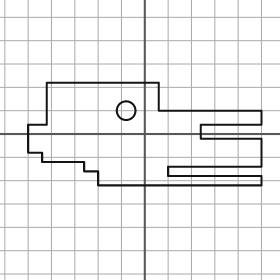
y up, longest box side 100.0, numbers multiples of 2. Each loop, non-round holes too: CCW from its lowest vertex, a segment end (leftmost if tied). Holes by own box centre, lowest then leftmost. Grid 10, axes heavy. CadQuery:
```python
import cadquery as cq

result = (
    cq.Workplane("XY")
    .moveTo(-20.0, -22.0)
    .lineTo(50.0, -22.0)
    .lineTo(50.0, -18.0)
    .lineTo(10.0, -18.0)
    .lineTo(10.0, -14.0)
    .lineTo(50.0, -14.0)
    .lineTo(50.0, -2.0)
    .lineTo(24.0, -2.0)
    .lineTo(24.0, 4.0)
    .lineTo(50.0, 4.0)
    .lineTo(50.0, 10.0)
    .lineTo(6.0, 10.0)
    .lineTo(6.0, 22.0)
    .lineTo(-42.0, 22.0)
    .lineTo(-42.0, 4.0)
    .lineTo(-50.0, 4.0)
    .lineTo(-50.0, -8.0)
    .lineTo(-44.0, -8.0)
    .lineTo(-44.0, -12.0)
    .lineTo(-26.0, -12.0)
    .lineTo(-26.0, -16.0)
    .lineTo(-20.0, -16.0)
    .close()
    .moveTo(-8.0, 10.0)
    .circle(4.0)
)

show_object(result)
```